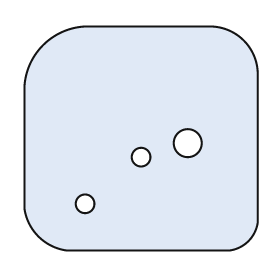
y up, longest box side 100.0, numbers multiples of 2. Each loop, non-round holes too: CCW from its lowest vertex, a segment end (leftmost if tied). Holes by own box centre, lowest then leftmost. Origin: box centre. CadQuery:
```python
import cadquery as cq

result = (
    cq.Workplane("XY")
    .moveTo(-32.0, -48.0)
    .lineTo(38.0, -48.0)
    .threePointArc((46.0, -44.0), (50.0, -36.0))
    .lineTo(50.0, 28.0)
    .threePointArc((44.0, 42.0), (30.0, 48.0))
    .lineTo(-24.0, 48.0)
    .threePointArc((-42.0, 40.0), (-50.0, 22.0))
    .lineTo(-50.0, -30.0)
    .threePointArc((-44.0, -42.0), (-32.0, -48.0))
    .close()
    .moveTo(-24.0, -28.0)
    .circle(4.0)
    .moveTo(0.0, -8.0)
    .circle(4.0)
    .moveTo(20.0, -2.0)
    .circle(6.0)
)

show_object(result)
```